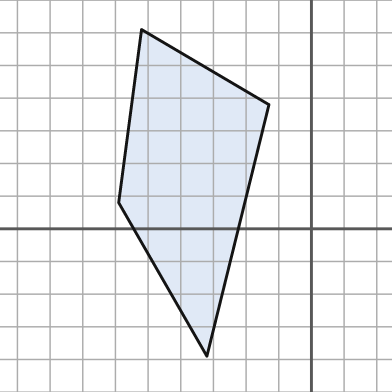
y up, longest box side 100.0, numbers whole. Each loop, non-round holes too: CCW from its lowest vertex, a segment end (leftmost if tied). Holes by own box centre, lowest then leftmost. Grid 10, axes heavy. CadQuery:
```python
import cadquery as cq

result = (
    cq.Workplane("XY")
    .moveTo(-32.0, -39.0)
    .lineTo(-13.0, 38.0)
    .lineTo(-52.0, 61.0)
    .lineTo(-59.0, 8.0)
    .close()
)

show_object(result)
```